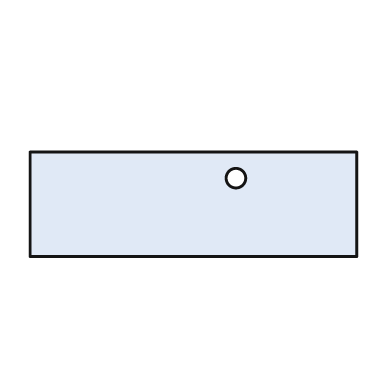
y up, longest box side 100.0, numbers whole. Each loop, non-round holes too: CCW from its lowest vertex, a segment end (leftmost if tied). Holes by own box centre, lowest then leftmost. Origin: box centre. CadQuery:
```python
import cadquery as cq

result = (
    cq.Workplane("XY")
    .moveTo(-50.0, -16.0)
    .lineTo(50.0, -16.0)
    .lineTo(50.0, 16.0)
    .lineTo(-50.0, 16.0)
    .close()
    .moveTo(13.0, 8.0)
    .circle(3.0)
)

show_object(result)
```